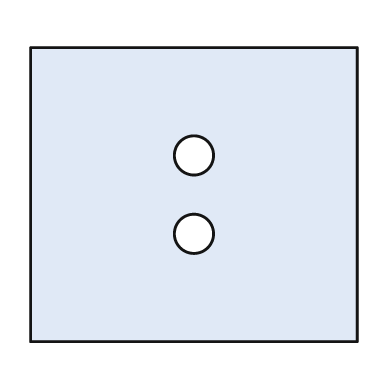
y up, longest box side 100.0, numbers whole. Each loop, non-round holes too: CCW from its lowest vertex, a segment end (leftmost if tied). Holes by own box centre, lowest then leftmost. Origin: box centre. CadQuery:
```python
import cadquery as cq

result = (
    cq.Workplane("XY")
    .moveTo(-50.0, -45.0)
    .lineTo(50.0, -45.0)
    .lineTo(50.0, 45.0)
    .lineTo(-50.0, 45.0)
    .close()
    .moveTo(0.0, -12.0)
    .circle(6.0)
    .moveTo(0.0, 12.0)
    .circle(6.0)
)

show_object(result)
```